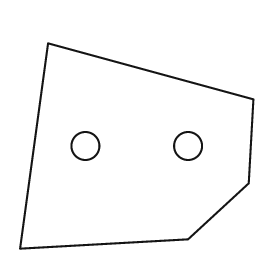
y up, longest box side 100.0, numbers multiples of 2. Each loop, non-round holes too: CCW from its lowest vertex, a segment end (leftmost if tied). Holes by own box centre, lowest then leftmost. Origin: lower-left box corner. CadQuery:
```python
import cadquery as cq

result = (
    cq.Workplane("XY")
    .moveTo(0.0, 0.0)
    .lineTo(72.0, 4.0)
    .lineTo(98.0, 28.0)
    .lineTo(100.0, 64.0)
    .lineTo(12.0, 88.0)
    .close()
    .moveTo(28.0, 44.0)
    .circle(6.0)
    .moveTo(72.0, 44.0)
    .circle(6.0)
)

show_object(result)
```